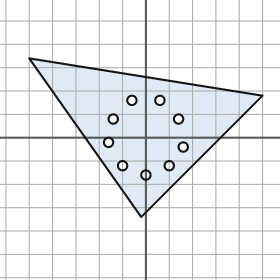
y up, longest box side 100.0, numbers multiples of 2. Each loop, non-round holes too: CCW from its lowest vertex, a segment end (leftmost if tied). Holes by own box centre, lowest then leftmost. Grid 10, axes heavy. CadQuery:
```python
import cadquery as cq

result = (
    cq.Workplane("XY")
    .moveTo(-2.0, -34.0)
    .lineTo(50.0, 18.0)
    .lineTo(-50.0, 34.0)
    .close()
    .moveTo(0.0, -16.0)
    .circle(2.0)
    .moveTo(-10.0, -12.0)
    .circle(2.0)
    .moveTo(10.0, -12.0)
    .circle(2.0)
    .moveTo(16.0, -4.0)
    .circle(2.0)
    .moveTo(-16.0, -2.0)
    .circle(2.0)
    .moveTo(-14.0, 8.0)
    .circle(2.0)
    .moveTo(14.0, 8.0)
    .circle(2.0)
    .moveTo(-6.0, 16.0)
    .circle(2.0)
    .moveTo(6.0, 16.0)
    .circle(2.0)
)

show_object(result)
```